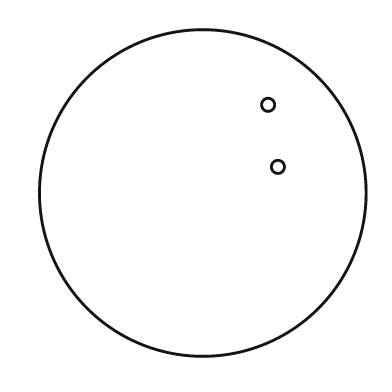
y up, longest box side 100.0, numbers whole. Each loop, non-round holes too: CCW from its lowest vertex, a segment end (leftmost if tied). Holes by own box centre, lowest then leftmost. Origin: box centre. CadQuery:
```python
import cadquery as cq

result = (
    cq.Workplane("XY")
    .moveTo(0.0, 0.0)
    .circle(50.0)
    .moveTo(23.0, 8.0)
    .circle(2.0)
    .moveTo(20.0, 27.0)
    .circle(2.0)
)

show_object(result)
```